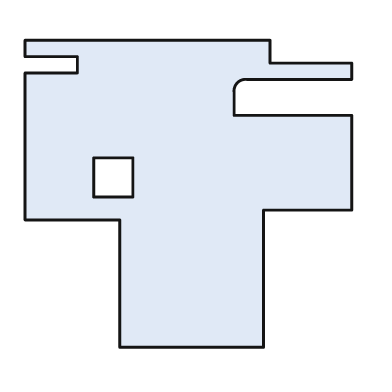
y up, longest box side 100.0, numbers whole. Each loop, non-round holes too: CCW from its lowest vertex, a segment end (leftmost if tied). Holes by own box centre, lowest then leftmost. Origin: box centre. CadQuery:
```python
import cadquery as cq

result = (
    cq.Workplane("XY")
    .moveTo(-21.0, -47.0)
    .lineTo(23.0, -47.0)
    .lineTo(23.0, -5.0)
    .lineTo(50.0, -5.0)
    .lineTo(50.0, 24.0)
    .lineTo(14.0, 24.0)
    .lineTo(14.0, 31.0)
    .threePointArc((15.0, 34.0), (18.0, 35.0))
    .lineTo(50.0, 35.0)
    .lineTo(50.0, 40.0)
    .lineTo(25.0, 40.0)
    .lineTo(25.0, 47.0)
    .lineTo(-50.0, 47.0)
    .lineTo(-50.0, 42.0)
    .lineTo(-34.0, 42.0)
    .lineTo(-34.0, 37.0)
    .lineTo(-50.0, 37.0)
    .lineTo(-50.0, -8.0)
    .lineTo(-21.0, -8.0)
    .close()
    .moveTo(-29.0, -1.0)
    .lineTo(-17.0, -1.0)
    .lineTo(-17.0, 11.0)
    .lineTo(-29.0, 11.0)
    .close()
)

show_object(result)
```